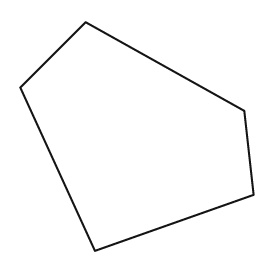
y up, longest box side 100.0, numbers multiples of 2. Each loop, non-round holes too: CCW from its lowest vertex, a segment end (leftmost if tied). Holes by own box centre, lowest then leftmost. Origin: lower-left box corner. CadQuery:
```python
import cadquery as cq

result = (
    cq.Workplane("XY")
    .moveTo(32.0, 0.0)
    .lineTo(100.0, 24.0)
    .lineTo(96.0, 60.0)
    .lineTo(28.0, 98.0)
    .lineTo(0.0, 70.0)
    .close()
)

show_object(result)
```